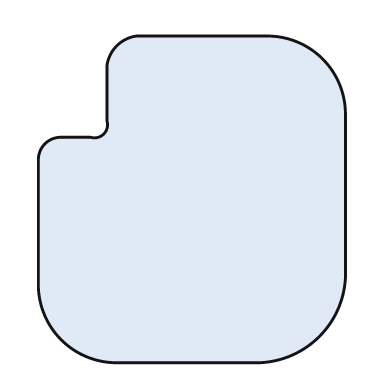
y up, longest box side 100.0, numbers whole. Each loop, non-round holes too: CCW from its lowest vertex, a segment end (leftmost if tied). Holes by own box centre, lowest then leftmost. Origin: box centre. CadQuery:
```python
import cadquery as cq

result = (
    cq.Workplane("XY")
    .moveTo(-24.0, -50.0)
    .lineTo(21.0, -50.0)
    .threePointArc((39.0, -42.0), (47.0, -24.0))
    .lineTo(47.0, 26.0)
    .threePointArc((40.0, 43.0), (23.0, 50.0))
    .lineTo(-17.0, 50.0)
    .threePointArc((-23.0, 47.0), (-26.0, 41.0))
    .lineTo(-26.0, 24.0)
    .threePointArc((-27.0, 20.0), (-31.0, 19.0))
    .lineTo(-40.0, 19.0)
    .threePointArc((-45.0, 17.0), (-47.0, 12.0))
    .lineTo(-47.0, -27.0)
    .threePointArc((-40.0, -43.0), (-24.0, -50.0))
    .close()
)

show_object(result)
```